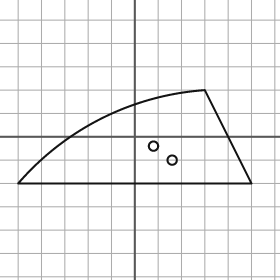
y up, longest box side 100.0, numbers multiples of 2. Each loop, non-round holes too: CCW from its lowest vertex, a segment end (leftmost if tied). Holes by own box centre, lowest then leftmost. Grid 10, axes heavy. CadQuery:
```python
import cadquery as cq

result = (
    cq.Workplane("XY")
    .moveTo(-50.0, -20.0)
    .lineTo(50.0, -20.0)
    .lineTo(30.0, 20.0)
    .threePointArc((-14.0, 8.0), (-50.0, -20.0))
    .close()
    .moveTo(16.0, -10.0)
    .circle(2.0)
    .moveTo(8.0, -4.0)
    .circle(2.0)
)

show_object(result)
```